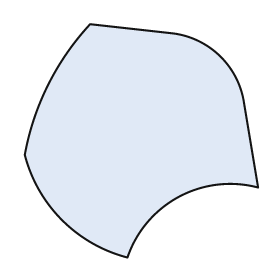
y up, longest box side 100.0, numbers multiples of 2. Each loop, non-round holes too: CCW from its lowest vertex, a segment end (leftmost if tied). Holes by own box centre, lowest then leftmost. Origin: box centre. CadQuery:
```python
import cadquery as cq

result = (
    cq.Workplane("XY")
    .moveTo(-6.0, -50.0)
    .threePointArc((16.0, -24.0), (50.0, -20.0))
    .lineTo(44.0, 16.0)
    .threePointArc((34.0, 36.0), (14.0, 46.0))
    .lineTo(-22.0, 50.0)
    .threePointArc((-40.0, 24.0), (-50.0, -6.0))
    .threePointArc((-34.0, -34.0), (-6.0, -50.0))
    .close()
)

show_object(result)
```